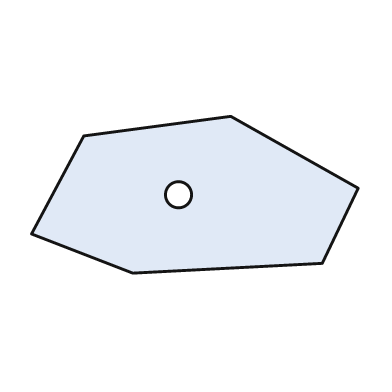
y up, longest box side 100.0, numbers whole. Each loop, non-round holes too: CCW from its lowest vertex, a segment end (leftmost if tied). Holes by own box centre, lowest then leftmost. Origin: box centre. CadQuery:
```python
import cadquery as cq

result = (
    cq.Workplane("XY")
    .moveTo(-19.0, -24.0)
    .lineTo(39.0, -21.0)
    .lineTo(50.0, 2.0)
    .lineTo(11.0, 24.0)
    .lineTo(-34.0, 18.0)
    .lineTo(-50.0, -12.0)
    .close()
    .moveTo(-5.0, 0.0)
    .circle(4.0)
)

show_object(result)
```